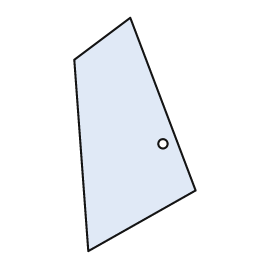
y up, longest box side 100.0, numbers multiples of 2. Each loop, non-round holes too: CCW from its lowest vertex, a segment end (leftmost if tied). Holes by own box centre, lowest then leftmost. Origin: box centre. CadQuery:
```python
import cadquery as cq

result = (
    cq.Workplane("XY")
    .moveTo(-20.0, -50.0)
    .lineTo(26.0, -24.0)
    .lineTo(-2.0, 50.0)
    .lineTo(-26.0, 32.0)
    .close()
    .moveTo(12.0, -4.0)
    .circle(2.0)
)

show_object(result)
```